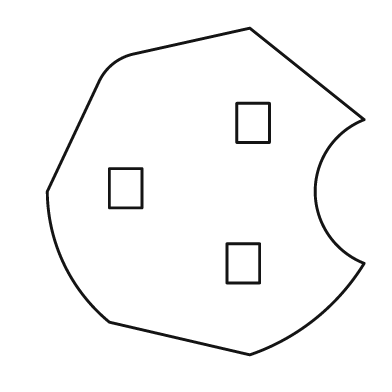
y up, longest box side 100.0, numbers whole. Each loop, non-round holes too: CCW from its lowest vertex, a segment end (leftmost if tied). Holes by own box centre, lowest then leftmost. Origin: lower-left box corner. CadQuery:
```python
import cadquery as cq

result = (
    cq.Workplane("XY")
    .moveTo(62.0, 0.0)
    .threePointArc((82.0, 11.0), (97.0, 28.0))
    .threePointArc((82.0, 50.0), (97.0, 72.0))
    .lineTo(62.0, 100.0)
    .lineTo(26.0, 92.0)
    .threePointArc((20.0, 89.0), (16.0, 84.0))
    .lineTo(0.0, 50.0)
    .threePointArc((5.0, 28.0), (19.0, 10.0))
    .close()
    .moveTo(55.0, 22.0)
    .lineTo(65.0, 22.0)
    .lineTo(65.0, 34.0)
    .lineTo(55.0, 34.0)
    .close()
    .moveTo(19.0, 45.0)
    .lineTo(29.0, 45.0)
    .lineTo(29.0, 57.0)
    .lineTo(19.0, 57.0)
    .close()
    .moveTo(58.0, 65.0)
    .lineTo(68.0, 65.0)
    .lineTo(68.0, 77.0)
    .lineTo(58.0, 77.0)
    .close()
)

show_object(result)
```